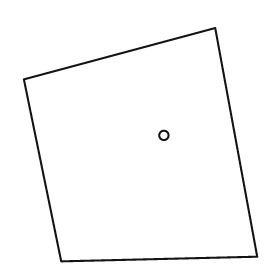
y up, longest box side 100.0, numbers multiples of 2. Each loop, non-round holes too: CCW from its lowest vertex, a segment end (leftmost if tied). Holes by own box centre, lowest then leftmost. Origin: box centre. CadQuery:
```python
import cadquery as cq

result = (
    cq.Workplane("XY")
    .moveTo(-34.0, -50.0)
    .lineTo(50.0, -48.0)
    .lineTo(32.0, 50.0)
    .lineTo(-50.0, 28.0)
    .close()
    .moveTo(10.0, 4.0)
    .circle(2.0)
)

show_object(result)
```